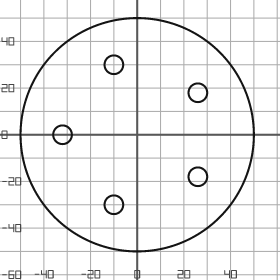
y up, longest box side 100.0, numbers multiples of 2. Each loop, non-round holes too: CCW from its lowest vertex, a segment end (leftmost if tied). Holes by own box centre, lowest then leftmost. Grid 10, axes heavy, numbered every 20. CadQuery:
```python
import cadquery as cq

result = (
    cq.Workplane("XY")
    .moveTo(0.0, 0.0)
    .circle(50.0)
    .moveTo(-10.0, -30.0)
    .circle(4.0)
    .moveTo(26.0, -18.0)
    .circle(4.0)
    .moveTo(-32.0, 0.0)
    .circle(4.0)
    .moveTo(26.0, 18.0)
    .circle(4.0)
    .moveTo(-10.0, 30.0)
    .circle(4.0)
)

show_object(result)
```